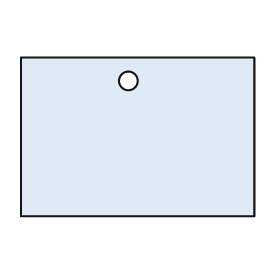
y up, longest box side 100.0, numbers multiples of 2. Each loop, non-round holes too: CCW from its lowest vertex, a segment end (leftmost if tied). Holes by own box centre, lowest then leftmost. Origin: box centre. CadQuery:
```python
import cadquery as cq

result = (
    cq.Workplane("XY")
    .moveTo(-50.0, -34.0)
    .lineTo(50.0, -34.0)
    .lineTo(50.0, 34.0)
    .lineTo(-50.0, 34.0)
    .close()
    .moveTo(-4.0, 24.0)
    .circle(4.0)
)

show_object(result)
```